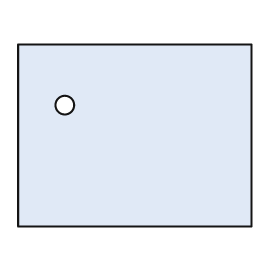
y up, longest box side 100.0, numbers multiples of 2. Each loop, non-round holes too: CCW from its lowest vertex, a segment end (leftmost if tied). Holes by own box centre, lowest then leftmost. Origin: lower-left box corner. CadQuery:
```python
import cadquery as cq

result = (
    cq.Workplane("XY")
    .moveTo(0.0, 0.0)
    .lineTo(100.0, 0.0)
    .lineTo(100.0, 78.0)
    .lineTo(0.0, 78.0)
    .close()
    .moveTo(20.0, 52.0)
    .circle(4.0)
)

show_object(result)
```